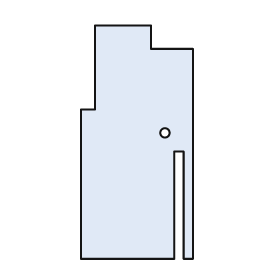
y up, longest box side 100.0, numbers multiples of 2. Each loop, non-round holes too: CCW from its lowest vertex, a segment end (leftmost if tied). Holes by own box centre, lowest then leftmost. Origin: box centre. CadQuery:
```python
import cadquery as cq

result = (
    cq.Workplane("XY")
    .moveTo(-24.0, -50.0)
    .lineTo(16.0, -50.0)
    .lineTo(16.0, -4.0)
    .lineTo(20.0, -4.0)
    .lineTo(20.0, -50.0)
    .lineTo(24.0, -50.0)
    .lineTo(24.0, 40.0)
    .lineTo(6.0, 40.0)
    .lineTo(6.0, 50.0)
    .lineTo(-18.0, 50.0)
    .lineTo(-18.0, 14.0)
    .lineTo(-24.0, 14.0)
    .close()
    .moveTo(12.0, 4.0)
    .circle(2.0)
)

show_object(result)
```